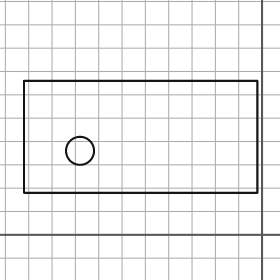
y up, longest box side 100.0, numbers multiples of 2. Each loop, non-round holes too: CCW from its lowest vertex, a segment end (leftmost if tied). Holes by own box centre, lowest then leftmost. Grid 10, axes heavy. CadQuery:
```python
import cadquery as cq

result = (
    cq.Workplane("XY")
    .moveTo(-102.0, 18.0)
    .lineTo(-2.0, 18.0)
    .lineTo(-2.0, 66.0)
    .lineTo(-102.0, 66.0)
    .close()
    .moveTo(-78.0, 36.0)
    .circle(6.0)
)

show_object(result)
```